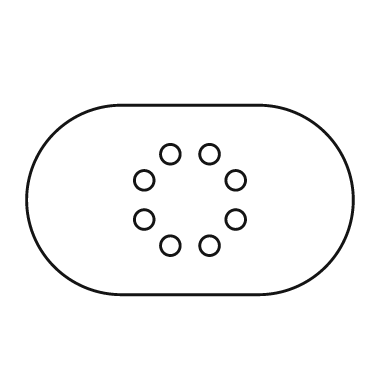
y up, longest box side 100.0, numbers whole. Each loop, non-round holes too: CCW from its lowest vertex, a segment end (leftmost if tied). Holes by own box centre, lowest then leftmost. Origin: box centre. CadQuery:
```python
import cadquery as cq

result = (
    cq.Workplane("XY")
    .moveTo(-21.0, -29.0)
    .lineTo(21.0, -29.0)
    .threePointArc((50.0, 0.0), (21.0, 29.0))
    .lineTo(-21.0, 29.0)
    .threePointArc((-50.0, 0.0), (-21.0, -29.0))
    .close()
    .moveTo(-6.0, -14.0)
    .circle(3.0)
    .moveTo(6.0, -14.0)
    .circle(3.0)
    .moveTo(-14.0, -6.0)
    .circle(3.0)
    .moveTo(14.0, -6.0)
    .circle(3.0)
    .moveTo(-14.0, 6.0)
    .circle(3.0)
    .moveTo(14.0, 6.0)
    .circle(3.0)
    .moveTo(-6.0, 14.0)
    .circle(3.0)
    .moveTo(6.0, 14.0)
    .circle(3.0)
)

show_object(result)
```